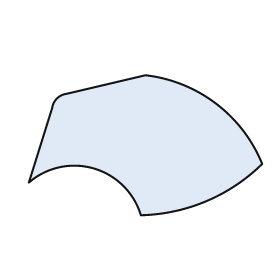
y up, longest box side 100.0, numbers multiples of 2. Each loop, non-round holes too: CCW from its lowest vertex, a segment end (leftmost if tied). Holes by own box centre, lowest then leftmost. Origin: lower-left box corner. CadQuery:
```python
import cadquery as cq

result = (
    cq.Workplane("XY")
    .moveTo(48.0, 0.0)
    .threePointArc((76.0, 6.0), (100.0, 22.0))
    .threePointArc((80.0, 48.0), (50.0, 60.0))
    .lineTo(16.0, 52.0)
    .threePointArc((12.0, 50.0), (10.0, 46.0))
    .lineTo(0.0, 14.0)
    .threePointArc((28.0, 20.0), (48.0, 0.0))
    .close()
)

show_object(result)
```